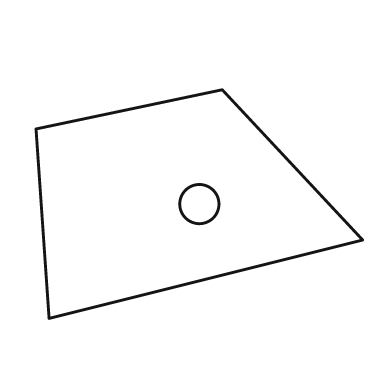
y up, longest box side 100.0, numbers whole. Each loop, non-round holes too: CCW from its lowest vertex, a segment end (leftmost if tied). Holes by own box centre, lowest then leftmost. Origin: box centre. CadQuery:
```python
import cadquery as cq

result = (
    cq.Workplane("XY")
    .moveTo(-46.0, -35.0)
    .lineTo(50.0, -11.0)
    .lineTo(7.0, 35.0)
    .lineTo(-50.0, 23.0)
    .close()
    .moveTo(0.0, 0.0)
    .circle(6.0)
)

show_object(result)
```